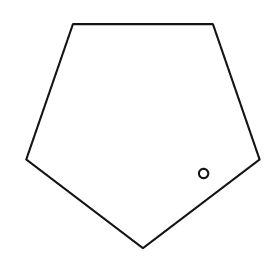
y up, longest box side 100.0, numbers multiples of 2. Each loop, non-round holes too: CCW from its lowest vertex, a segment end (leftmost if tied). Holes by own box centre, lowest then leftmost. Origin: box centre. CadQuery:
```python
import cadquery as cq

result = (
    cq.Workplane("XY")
    .moveTo(0.0, -48.0)
    .lineTo(50.0, -10.0)
    .lineTo(30.0, 48.0)
    .lineTo(-30.0, 48.0)
    .lineTo(-50.0, -10.0)
    .close()
    .moveTo(26.0, -16.0)
    .circle(2.0)
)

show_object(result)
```